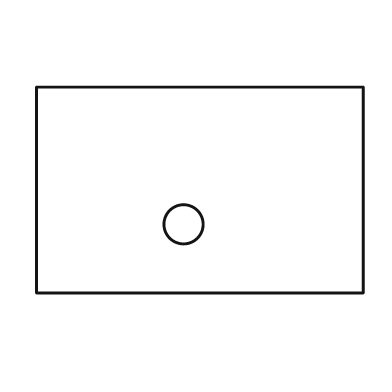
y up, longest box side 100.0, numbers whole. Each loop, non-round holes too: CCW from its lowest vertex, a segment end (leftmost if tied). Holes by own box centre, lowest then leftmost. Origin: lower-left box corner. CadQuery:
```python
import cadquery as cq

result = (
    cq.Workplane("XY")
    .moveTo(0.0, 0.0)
    .lineTo(100.0, 0.0)
    .lineTo(100.0, 63.0)
    .lineTo(0.0, 63.0)
    .close()
    .moveTo(45.0, 21.0)
    .circle(6.0)
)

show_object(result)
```